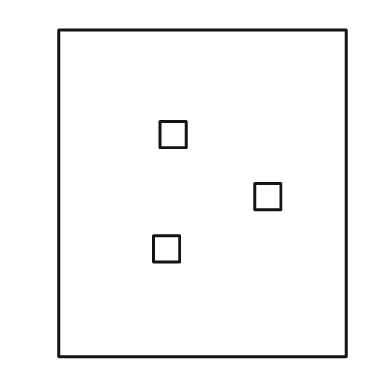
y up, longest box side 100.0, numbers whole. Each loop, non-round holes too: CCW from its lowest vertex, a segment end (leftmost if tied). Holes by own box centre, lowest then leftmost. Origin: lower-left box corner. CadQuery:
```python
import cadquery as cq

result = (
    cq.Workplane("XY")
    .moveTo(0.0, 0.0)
    .lineTo(88.0, 0.0)
    .lineTo(88.0, 100.0)
    .lineTo(0.0, 100.0)
    .close()
    .moveTo(29.0, 29.0)
    .lineTo(37.0, 29.0)
    .lineTo(37.0, 37.0)
    .lineTo(29.0, 37.0)
    .close()
    .moveTo(60.0, 45.0)
    .lineTo(68.0, 45.0)
    .lineTo(68.0, 53.0)
    .lineTo(60.0, 53.0)
    .close()
    .moveTo(31.0, 64.0)
    .lineTo(39.0, 64.0)
    .lineTo(39.0, 72.0)
    .lineTo(31.0, 72.0)
    .close()
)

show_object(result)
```